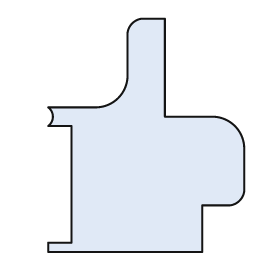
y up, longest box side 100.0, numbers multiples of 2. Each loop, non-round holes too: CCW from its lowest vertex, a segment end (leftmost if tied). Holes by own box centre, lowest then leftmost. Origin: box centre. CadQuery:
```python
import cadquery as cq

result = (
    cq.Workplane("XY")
    .moveTo(-42.0, -50.0)
    .lineTo(24.0, -50.0)
    .lineTo(24.0, -30.0)
    .lineTo(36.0, -30.0)
    .threePointArc((40.0, -28.0), (42.0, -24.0))
    .lineTo(42.0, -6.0)
    .threePointArc((38.0, 4.0), (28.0, 8.0))
    .lineTo(8.0, 8.0)
    .lineTo(8.0, 50.0)
    .lineTo(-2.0, 50.0)
    .threePointArc((-6.0, 48.0), (-8.0, 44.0))
    .lineTo(-8.0, 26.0)
    .threePointArc((-12.0, 16.0), (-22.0, 12.0))
    .lineTo(-42.0, 12.0)
    .threePointArc((-40.0, 8.0), (-42.0, 4.0))
    .lineTo(-32.0, 4.0)
    .lineTo(-32.0, -46.0)
    .lineTo(-42.0, -46.0)
    .close()
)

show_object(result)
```